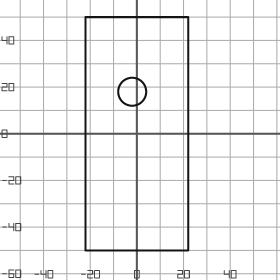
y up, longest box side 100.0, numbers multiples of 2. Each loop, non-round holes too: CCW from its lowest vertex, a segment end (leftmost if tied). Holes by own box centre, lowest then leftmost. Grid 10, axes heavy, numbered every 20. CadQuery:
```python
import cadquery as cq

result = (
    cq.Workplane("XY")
    .moveTo(-22.0, -50.0)
    .lineTo(22.0, -50.0)
    .lineTo(22.0, 50.0)
    .lineTo(-22.0, 50.0)
    .close()
    .moveTo(-2.0, 18.0)
    .circle(6.0)
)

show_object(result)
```